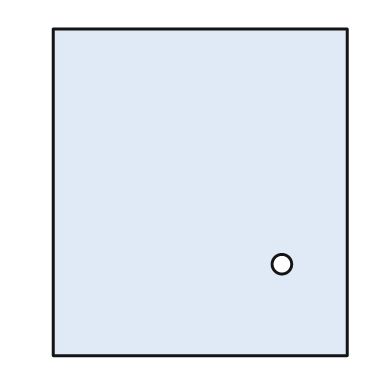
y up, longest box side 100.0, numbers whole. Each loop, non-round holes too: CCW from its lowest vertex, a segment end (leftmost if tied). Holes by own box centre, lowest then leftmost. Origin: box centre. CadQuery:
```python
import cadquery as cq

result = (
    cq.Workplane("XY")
    .moveTo(-45.0, -50.0)
    .lineTo(45.0, -50.0)
    .lineTo(45.0, 50.0)
    .lineTo(-45.0, 50.0)
    .close()
    .moveTo(25.0, -22.0)
    .circle(3.0)
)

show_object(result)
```